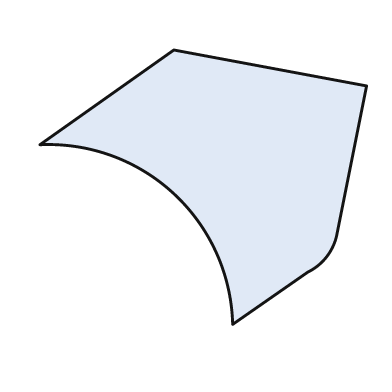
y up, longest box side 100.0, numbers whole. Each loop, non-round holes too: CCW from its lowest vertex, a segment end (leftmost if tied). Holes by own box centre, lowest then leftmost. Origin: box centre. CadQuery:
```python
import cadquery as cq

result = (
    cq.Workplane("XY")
    .moveTo(9.0, -42.0)
    .lineTo(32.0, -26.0)
    .threePointArc((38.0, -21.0), (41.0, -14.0))
    .lineTo(50.0, 31.0)
    .lineTo(-9.0, 42.0)
    .lineTo(-50.0, 13.0)
    .threePointArc((-9.0, -2.0), (9.0, -42.0))
    .close()
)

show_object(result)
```